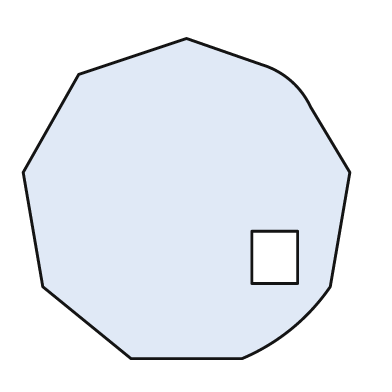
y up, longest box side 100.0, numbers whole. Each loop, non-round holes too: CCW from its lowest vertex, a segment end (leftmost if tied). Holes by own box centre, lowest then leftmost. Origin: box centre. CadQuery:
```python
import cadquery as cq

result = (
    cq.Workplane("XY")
    .moveTo(-17.0, -49.0)
    .lineTo(17.0, -49.0)
    .threePointArc((32.0, -40.0), (44.0, -27.0))
    .lineTo(50.0, 8.0)
    .lineTo(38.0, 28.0)
    .threePointArc((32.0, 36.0), (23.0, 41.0))
    .lineTo(0.0, 49.0)
    .lineTo(-33.0, 38.0)
    .lineTo(-50.0, 8.0)
    .lineTo(-44.0, -27.0)
    .close()
    .moveTo(20.0, -26.0)
    .lineTo(34.0, -26.0)
    .lineTo(34.0, -10.0)
    .lineTo(20.0, -10.0)
    .close()
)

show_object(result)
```